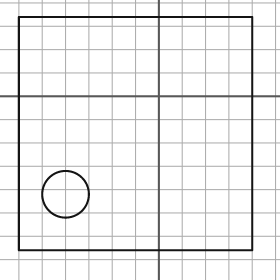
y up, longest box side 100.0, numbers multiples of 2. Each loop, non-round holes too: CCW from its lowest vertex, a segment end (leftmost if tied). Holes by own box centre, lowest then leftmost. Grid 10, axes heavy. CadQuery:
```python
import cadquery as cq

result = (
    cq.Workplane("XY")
    .moveTo(-60.0, -66.0)
    .lineTo(40.0, -66.0)
    .lineTo(40.0, 34.0)
    .lineTo(-60.0, 34.0)
    .close()
    .moveTo(-40.0, -42.0)
    .circle(10.0)
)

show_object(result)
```